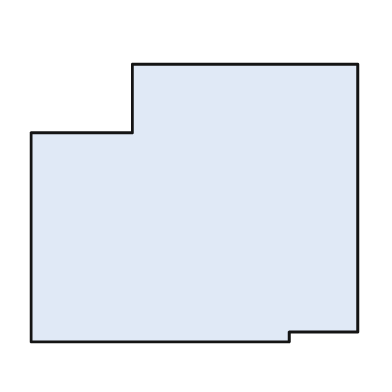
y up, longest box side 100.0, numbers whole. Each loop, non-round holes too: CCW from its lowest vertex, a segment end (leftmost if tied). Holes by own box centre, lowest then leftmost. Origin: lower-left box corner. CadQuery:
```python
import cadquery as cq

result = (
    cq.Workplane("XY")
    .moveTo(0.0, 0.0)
    .lineTo(79.0, 0.0)
    .lineTo(79.0, 3.0)
    .lineTo(100.0, 3.0)
    .lineTo(100.0, 85.0)
    .lineTo(31.0, 85.0)
    .lineTo(31.0, 64.0)
    .lineTo(0.0, 64.0)
    .close()
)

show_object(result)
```